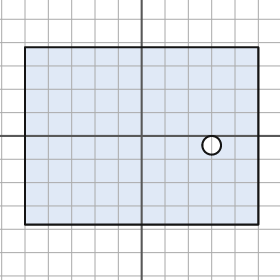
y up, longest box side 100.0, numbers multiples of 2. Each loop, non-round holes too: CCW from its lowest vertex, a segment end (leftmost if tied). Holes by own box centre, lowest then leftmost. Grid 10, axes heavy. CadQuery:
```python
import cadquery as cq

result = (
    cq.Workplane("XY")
    .moveTo(-50.0, -38.0)
    .lineTo(50.0, -38.0)
    .lineTo(50.0, 38.0)
    .lineTo(-50.0, 38.0)
    .close()
    .moveTo(30.0, -4.0)
    .circle(4.0)
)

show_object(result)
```